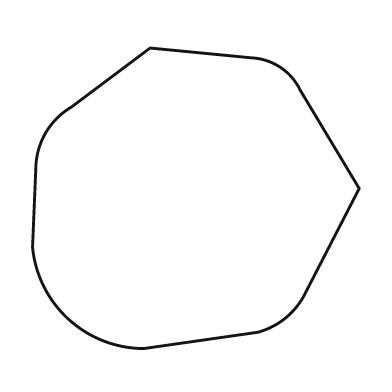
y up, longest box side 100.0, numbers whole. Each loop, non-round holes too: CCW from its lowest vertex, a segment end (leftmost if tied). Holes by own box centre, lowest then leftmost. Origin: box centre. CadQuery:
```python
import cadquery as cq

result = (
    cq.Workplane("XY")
    .moveTo(-16.0, -46.0)
    .lineTo(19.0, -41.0)
    .threePointArc((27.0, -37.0), (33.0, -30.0))
    .lineTo(50.0, 3.0)
    .lineTo(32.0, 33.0)
    .threePointArc((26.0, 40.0), (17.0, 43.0))
    .lineTo(-14.0, 46.0)
    .lineTo(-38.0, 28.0)
    .threePointArc((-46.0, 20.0), (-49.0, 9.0))
    .lineTo(-50.0, -15.0)
    .threePointArc((-39.0, -37.0), (-16.0, -46.0))
    .close()
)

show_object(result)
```